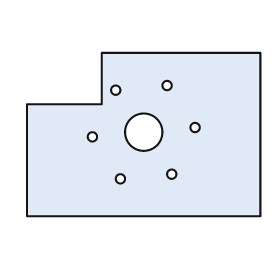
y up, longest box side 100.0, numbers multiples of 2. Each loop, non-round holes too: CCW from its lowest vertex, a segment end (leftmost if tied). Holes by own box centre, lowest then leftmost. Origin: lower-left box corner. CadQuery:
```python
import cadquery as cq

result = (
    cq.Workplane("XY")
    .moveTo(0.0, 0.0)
    .lineTo(100.0, 0.0)
    .lineTo(100.0, 70.0)
    .lineTo(32.0, 70.0)
    .lineTo(32.0, 48.0)
    .lineTo(0.0, 48.0)
    .close()
    .moveTo(40.0, 16.0)
    .circle(2.0)
    .moveTo(62.0, 18.0)
    .circle(2.0)
    .moveTo(28.0, 34.0)
    .circle(2.0)
    .moveTo(50.0, 36.0)
    .circle(8.0)
    .moveTo(72.0, 38.0)
    .circle(2.0)
    .moveTo(38.0, 54.0)
    .circle(2.0)
    .moveTo(60.0, 56.0)
    .circle(2.0)
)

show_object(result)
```